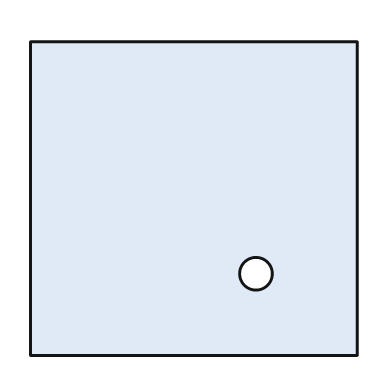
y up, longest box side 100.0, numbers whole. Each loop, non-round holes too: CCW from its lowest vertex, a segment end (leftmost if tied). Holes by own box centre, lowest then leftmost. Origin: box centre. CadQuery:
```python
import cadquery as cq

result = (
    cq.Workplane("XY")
    .moveTo(-50.0, -48.0)
    .lineTo(50.0, -48.0)
    .lineTo(50.0, 48.0)
    .lineTo(-50.0, 48.0)
    .close()
    .moveTo(19.0, -23.0)
    .circle(5.0)
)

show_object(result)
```